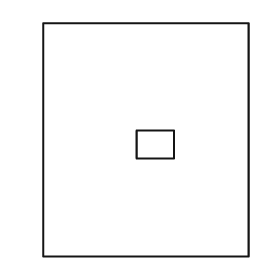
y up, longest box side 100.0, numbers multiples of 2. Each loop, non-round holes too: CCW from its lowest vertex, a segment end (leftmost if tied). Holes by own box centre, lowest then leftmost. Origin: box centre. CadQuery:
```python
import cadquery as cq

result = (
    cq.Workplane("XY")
    .moveTo(-44.0, -50.0)
    .lineTo(44.0, -50.0)
    .lineTo(44.0, 50.0)
    .lineTo(-44.0, 50.0)
    .close()
    .moveTo(-4.0, -8.0)
    .lineTo(12.0, -8.0)
    .lineTo(12.0, 4.0)
    .lineTo(-4.0, 4.0)
    .close()
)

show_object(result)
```